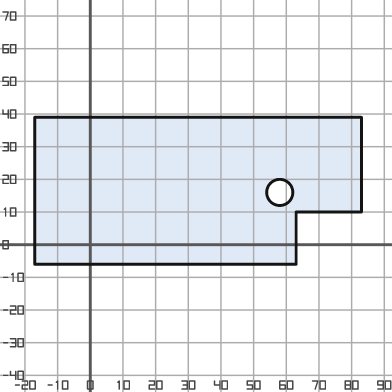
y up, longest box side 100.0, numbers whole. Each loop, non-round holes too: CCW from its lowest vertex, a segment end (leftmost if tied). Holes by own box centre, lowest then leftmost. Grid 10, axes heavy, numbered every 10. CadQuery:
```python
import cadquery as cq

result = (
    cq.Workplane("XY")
    .moveTo(-17.0, -6.0)
    .lineTo(63.0, -6.0)
    .lineTo(63.0, 10.0)
    .lineTo(83.0, 10.0)
    .lineTo(83.0, 39.0)
    .lineTo(-17.0, 39.0)
    .close()
    .moveTo(58.0, 16.0)
    .circle(4.0)
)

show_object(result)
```